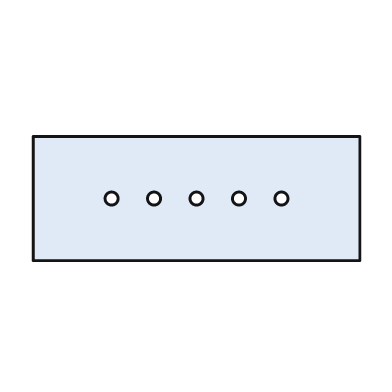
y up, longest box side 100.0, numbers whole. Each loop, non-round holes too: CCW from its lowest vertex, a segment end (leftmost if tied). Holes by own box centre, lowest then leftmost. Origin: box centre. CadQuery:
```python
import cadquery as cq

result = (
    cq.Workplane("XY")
    .moveTo(-50.0, -19.0)
    .lineTo(50.0, -19.0)
    .lineTo(50.0, 19.0)
    .lineTo(-50.0, 19.0)
    .close()
    .moveTo(-26.0, 0.0)
    .circle(2.0)
    .moveTo(-13.0, 0.0)
    .circle(2.0)
    .moveTo(0.0, 0.0)
    .circle(2.0)
    .moveTo(13.0, 0.0)
    .circle(2.0)
    .moveTo(26.0, 0.0)
    .circle(2.0)
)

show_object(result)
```